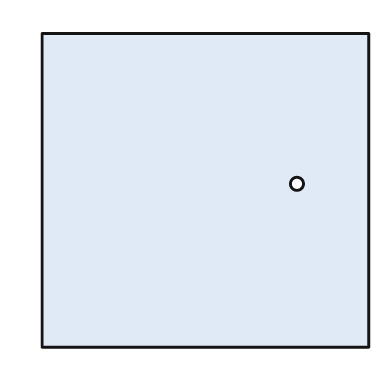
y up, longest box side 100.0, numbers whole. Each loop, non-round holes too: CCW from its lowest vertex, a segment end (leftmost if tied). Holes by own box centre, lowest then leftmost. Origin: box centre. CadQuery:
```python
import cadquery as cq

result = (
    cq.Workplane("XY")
    .moveTo(-50.0, -48.0)
    .lineTo(50.0, -48.0)
    .lineTo(50.0, 48.0)
    .lineTo(-50.0, 48.0)
    .close()
    .moveTo(28.0, 2.0)
    .circle(2.0)
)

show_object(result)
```